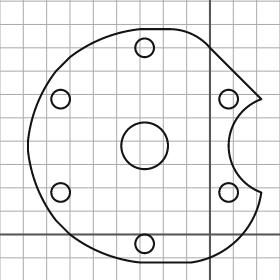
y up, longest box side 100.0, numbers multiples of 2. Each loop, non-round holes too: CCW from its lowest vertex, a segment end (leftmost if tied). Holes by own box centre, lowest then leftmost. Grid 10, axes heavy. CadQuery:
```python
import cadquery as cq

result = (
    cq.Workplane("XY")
    .moveTo(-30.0, -12.0)
    .lineTo(-8.0, -12.0)
    .threePointArc((12.0, -2.0), (22.0, 18.0))
    .threePointArc((8.0, 38.0), (22.0, 58.0))
    .lineTo(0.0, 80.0)
    .threePointArc((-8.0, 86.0), (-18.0, 88.0))
    .lineTo(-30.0, 88.0)
    .threePointArc((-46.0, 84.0), (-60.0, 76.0))
    .lineTo(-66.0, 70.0)
    .threePointArc((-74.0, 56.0), (-78.0, 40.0))
    .lineTo(-78.0, 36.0)
    .threePointArc((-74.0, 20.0), (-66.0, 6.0))
    .lineTo(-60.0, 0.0)
    .threePointArc((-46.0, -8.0), (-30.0, -12.0))
    .close()
    .moveTo(-28.0, -4.0)
    .circle(4.0)
    .moveTo(-64.0, 18.0)
    .circle(4.0)
    .moveTo(8.0, 18.0)
    .circle(4.0)
    .moveTo(-28.0, 38.0)
    .circle(10.0)
    .moveTo(-64.0, 58.0)
    .circle(4.0)
    .moveTo(8.0, 58.0)
    .circle(4.0)
    .moveTo(-28.0, 80.0)
    .circle(4.0)
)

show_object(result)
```